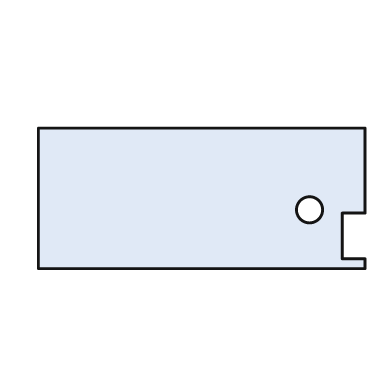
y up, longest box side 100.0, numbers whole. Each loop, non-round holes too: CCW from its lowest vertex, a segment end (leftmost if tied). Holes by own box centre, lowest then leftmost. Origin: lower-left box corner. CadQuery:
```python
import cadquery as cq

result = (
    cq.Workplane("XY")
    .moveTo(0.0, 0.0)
    .lineTo(100.0, 0.0)
    .lineTo(100.0, 3.0)
    .lineTo(93.0, 3.0)
    .lineTo(93.0, 17.0)
    .lineTo(100.0, 17.0)
    .lineTo(100.0, 43.0)
    .lineTo(0.0, 43.0)
    .close()
    .moveTo(83.0, 18.0)
    .circle(4.0)
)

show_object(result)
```